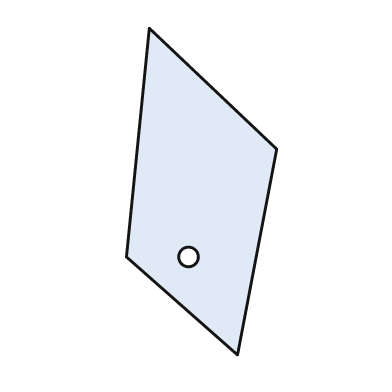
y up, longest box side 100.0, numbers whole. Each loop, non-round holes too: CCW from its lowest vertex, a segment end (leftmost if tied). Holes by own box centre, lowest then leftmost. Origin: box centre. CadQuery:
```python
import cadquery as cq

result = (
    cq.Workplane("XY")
    .moveTo(11.0, -50.0)
    .lineTo(23.0, 13.0)
    .lineTo(-16.0, 50.0)
    .lineTo(-23.0, -20.0)
    .close()
    .moveTo(-4.0, -20.0)
    .circle(3.0)
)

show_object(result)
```